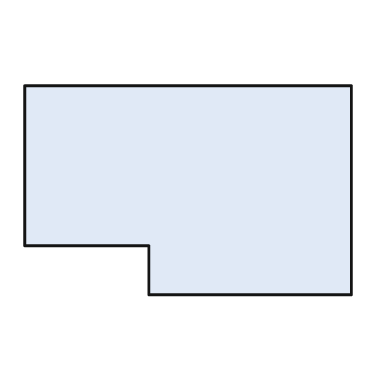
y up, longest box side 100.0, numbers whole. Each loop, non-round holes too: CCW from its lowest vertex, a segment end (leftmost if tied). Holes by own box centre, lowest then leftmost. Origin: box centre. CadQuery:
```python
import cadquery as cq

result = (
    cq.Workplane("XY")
    .moveTo(-12.0, -32.0)
    .lineTo(50.0, -32.0)
    .lineTo(50.0, 32.0)
    .lineTo(-50.0, 32.0)
    .lineTo(-50.0, -17.0)
    .lineTo(-12.0, -17.0)
    .close()
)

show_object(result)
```